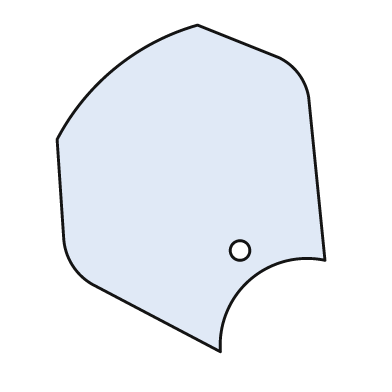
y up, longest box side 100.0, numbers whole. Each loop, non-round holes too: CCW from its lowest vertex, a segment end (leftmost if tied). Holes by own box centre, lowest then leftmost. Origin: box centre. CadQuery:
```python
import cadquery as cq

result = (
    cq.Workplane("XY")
    .moveTo(9.0, -50.0)
    .threePointArc((18.0, -28.0), (41.0, -22.0))
    .lineTo(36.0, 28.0)
    .threePointArc((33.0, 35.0), (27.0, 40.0))
    .lineTo(2.0, 50.0)
    .threePointArc((-23.0, 37.0), (-41.0, 15.0))
    .lineTo(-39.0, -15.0)
    .threePointArc((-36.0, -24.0), (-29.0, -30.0))
    .close()
    .moveTo(15.0, -19.0)
    .circle(3.0)
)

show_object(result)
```